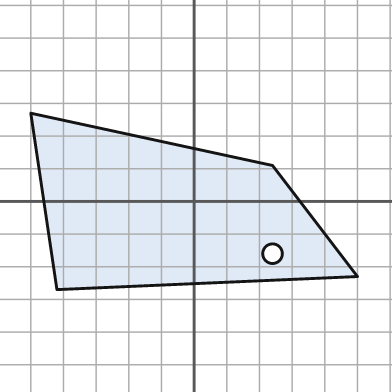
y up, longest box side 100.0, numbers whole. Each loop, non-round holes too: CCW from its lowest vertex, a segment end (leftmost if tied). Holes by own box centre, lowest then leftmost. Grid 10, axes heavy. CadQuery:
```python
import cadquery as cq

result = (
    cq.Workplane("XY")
    .moveTo(-42.0, -27.0)
    .lineTo(50.0, -23.0)
    .lineTo(24.0, 11.0)
    .lineTo(-50.0, 27.0)
    .close()
    .moveTo(24.0, -16.0)
    .circle(3.0)
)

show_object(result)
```